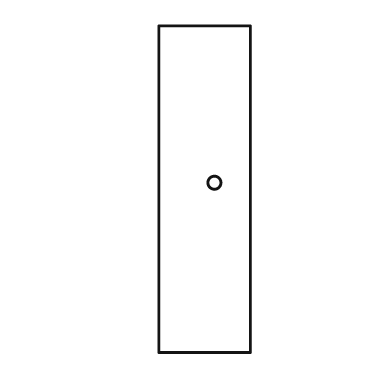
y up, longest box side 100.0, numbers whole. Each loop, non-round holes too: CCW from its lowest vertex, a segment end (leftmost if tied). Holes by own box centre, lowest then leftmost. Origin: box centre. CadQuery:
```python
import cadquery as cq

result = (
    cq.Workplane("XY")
    .moveTo(-14.0, -50.0)
    .lineTo(14.0, -50.0)
    .lineTo(14.0, 50.0)
    .lineTo(-14.0, 50.0)
    .close()
    .moveTo(3.0, 2.0)
    .circle(2.0)
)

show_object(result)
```